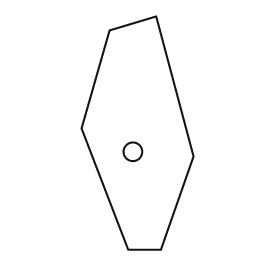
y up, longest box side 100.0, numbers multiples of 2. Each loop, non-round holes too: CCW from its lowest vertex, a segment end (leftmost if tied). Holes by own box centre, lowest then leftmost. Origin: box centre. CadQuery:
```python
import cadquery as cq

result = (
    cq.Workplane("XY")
    .moveTo(-4.0, -50.0)
    .lineTo(10.0, -50.0)
    .lineTo(24.0, -10.0)
    .lineTo(8.0, 50.0)
    .lineTo(-12.0, 44.0)
    .lineTo(-24.0, 2.0)
    .close()
    .moveTo(-2.0, -8.0)
    .circle(4.0)
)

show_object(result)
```